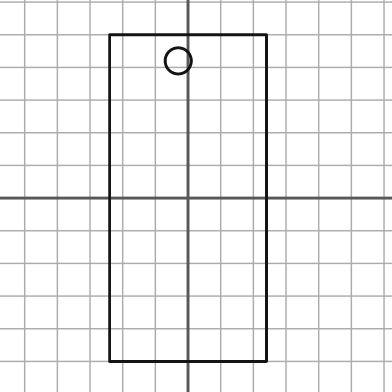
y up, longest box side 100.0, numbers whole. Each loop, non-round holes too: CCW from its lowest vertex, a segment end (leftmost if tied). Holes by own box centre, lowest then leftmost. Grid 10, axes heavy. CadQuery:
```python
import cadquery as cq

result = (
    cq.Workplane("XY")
    .moveTo(-24.0, -50.0)
    .lineTo(24.0, -50.0)
    .lineTo(24.0, 50.0)
    .lineTo(-24.0, 50.0)
    .close()
    .moveTo(-3.0, 42.0)
    .circle(4.0)
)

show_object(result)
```